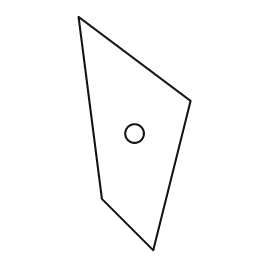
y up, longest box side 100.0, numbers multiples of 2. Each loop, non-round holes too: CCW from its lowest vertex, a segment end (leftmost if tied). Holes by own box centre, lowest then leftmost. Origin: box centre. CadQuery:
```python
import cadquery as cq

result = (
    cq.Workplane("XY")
    .moveTo(8.0, -50.0)
    .lineTo(24.0, 14.0)
    .lineTo(-24.0, 50.0)
    .lineTo(-14.0, -28.0)
    .close()
    .moveTo(0.0, 0.0)
    .circle(4.0)
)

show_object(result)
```